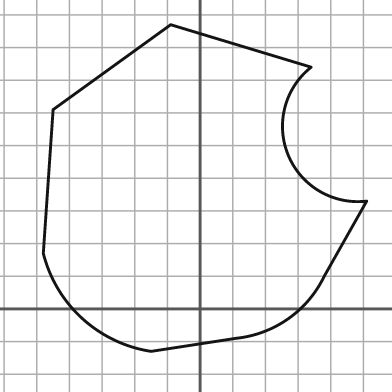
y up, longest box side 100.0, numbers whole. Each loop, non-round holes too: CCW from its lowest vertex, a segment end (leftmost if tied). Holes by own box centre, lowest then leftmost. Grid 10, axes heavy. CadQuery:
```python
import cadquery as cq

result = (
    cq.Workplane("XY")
    .moveTo(-15.0, -13.0)
    .lineTo(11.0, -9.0)
    .threePointArc((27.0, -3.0), (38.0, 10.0))
    .lineTo(51.0, 33.0)
    .threePointArc((27.0, 47.0), (34.0, 74.0))
    .lineTo(-9.0, 87.0)
    .lineTo(-45.0, 61.0)
    .lineTo(-48.0, 17.0)
    .threePointArc((-36.0, -3.0), (-15.0, -13.0))
    .close()
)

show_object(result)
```